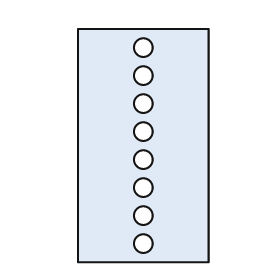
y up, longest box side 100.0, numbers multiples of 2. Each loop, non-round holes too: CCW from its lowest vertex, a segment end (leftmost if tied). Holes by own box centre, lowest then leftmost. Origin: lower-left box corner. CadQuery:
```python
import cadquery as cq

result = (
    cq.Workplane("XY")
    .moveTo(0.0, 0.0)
    .lineTo(56.0, 0.0)
    .lineTo(56.0, 100.0)
    .lineTo(0.0, 100.0)
    .close()
    .moveTo(28.0, 8.0)
    .circle(4.0)
    .moveTo(28.0, 20.0)
    .circle(4.0)
    .moveTo(28.0, 32.0)
    .circle(4.0)
    .moveTo(28.0, 44.0)
    .circle(4.0)
    .moveTo(28.0, 56.0)
    .circle(4.0)
    .moveTo(28.0, 68.0)
    .circle(4.0)
    .moveTo(28.0, 80.0)
    .circle(4.0)
    .moveTo(28.0, 92.0)
    .circle(4.0)
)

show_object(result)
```